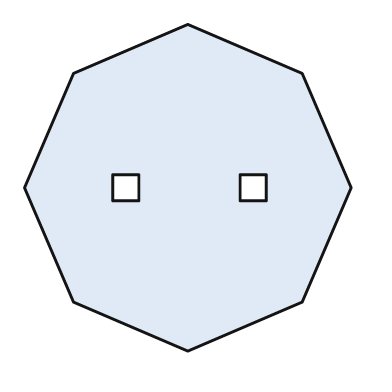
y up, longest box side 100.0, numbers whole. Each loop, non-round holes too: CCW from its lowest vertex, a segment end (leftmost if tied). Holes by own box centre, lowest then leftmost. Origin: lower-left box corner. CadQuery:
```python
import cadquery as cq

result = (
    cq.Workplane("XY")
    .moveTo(50.0, 0.0)
    .lineTo(85.0, 15.0)
    .lineTo(100.0, 50.0)
    .lineTo(85.0, 85.0)
    .lineTo(50.0, 100.0)
    .lineTo(15.0, 85.0)
    .lineTo(0.0, 50.0)
    .lineTo(15.0, 15.0)
    .close()
    .moveTo(27.0, 46.0)
    .lineTo(35.0, 46.0)
    .lineTo(35.0, 54.0)
    .lineTo(27.0, 54.0)
    .close()
    .moveTo(66.0, 46.0)
    .lineTo(74.0, 46.0)
    .lineTo(74.0, 54.0)
    .lineTo(66.0, 54.0)
    .close()
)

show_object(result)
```